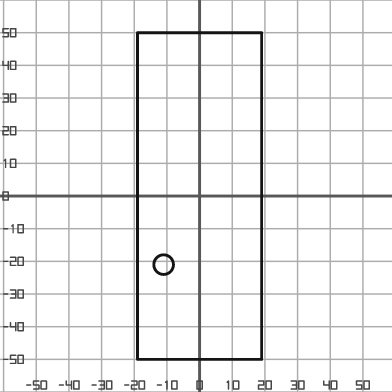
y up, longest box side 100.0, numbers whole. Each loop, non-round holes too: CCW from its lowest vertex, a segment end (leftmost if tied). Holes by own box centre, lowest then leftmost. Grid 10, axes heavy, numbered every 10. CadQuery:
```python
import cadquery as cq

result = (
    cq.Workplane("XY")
    .moveTo(-19.0, -50.0)
    .lineTo(19.0, -50.0)
    .lineTo(19.0, 50.0)
    .lineTo(-19.0, 50.0)
    .close()
    .moveTo(-11.0, -21.0)
    .circle(3.0)
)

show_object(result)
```